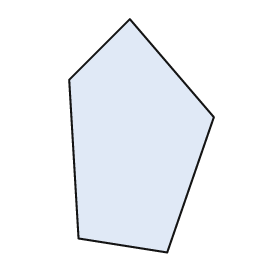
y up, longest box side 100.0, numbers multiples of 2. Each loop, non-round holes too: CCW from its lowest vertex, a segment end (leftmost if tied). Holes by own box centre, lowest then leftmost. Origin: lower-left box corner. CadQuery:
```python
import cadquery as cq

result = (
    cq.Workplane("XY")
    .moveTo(42.0, 0.0)
    .lineTo(62.0, 58.0)
    .lineTo(26.0, 100.0)
    .lineTo(0.0, 74.0)
    .lineTo(4.0, 6.0)
    .close()
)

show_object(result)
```